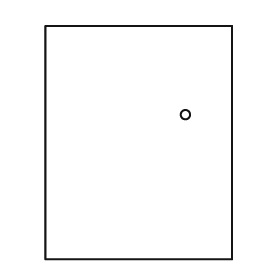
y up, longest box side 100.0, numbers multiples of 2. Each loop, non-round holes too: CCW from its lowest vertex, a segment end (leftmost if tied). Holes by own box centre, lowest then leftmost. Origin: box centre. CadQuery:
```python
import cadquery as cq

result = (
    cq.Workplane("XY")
    .moveTo(-40.0, -50.0)
    .lineTo(40.0, -50.0)
    .lineTo(40.0, 50.0)
    .lineTo(-40.0, 50.0)
    .close()
    .moveTo(20.0, 12.0)
    .circle(2.0)
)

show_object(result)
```